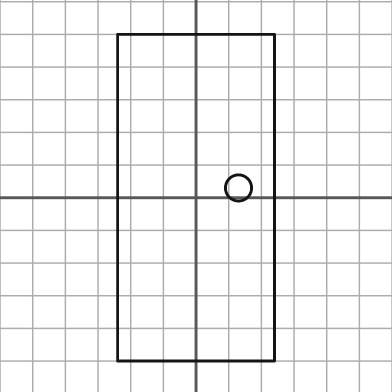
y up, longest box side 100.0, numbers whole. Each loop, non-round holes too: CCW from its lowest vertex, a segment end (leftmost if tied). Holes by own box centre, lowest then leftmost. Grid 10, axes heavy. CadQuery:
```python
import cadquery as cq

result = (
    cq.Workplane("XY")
    .moveTo(-24.0, -50.0)
    .lineTo(24.0, -50.0)
    .lineTo(24.0, 50.0)
    .lineTo(-24.0, 50.0)
    .close()
    .moveTo(13.0, 3.0)
    .circle(4.0)
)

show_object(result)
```